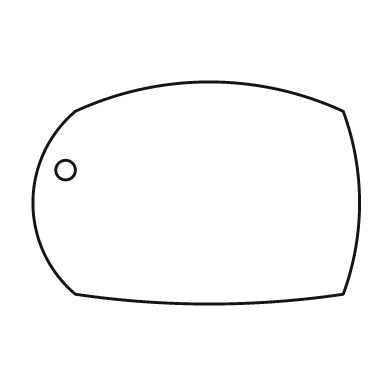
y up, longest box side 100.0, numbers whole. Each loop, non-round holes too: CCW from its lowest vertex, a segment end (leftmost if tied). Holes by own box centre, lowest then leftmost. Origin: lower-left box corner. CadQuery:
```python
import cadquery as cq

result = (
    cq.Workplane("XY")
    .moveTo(13.0, 3.0)
    .threePointArc((54.0, 0.0), (95.0, 3.0))
    .threePointArc((100.0, 31.0), (95.0, 59.0))
    .threePointArc((54.0, 68.0), (13.0, 59.0))
    .threePointArc((0.0, 31.0), (13.0, 3.0))
    .close()
    .moveTo(10.0, 41.0)
    .circle(3.0)
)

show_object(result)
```